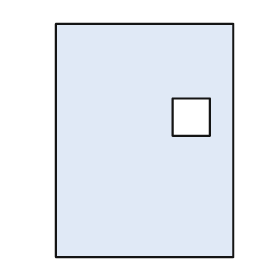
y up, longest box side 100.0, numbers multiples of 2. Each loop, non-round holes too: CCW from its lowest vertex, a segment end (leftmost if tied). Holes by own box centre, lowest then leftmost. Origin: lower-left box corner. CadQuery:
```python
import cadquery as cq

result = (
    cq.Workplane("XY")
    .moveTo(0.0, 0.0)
    .lineTo(76.0, 0.0)
    .lineTo(76.0, 100.0)
    .lineTo(0.0, 100.0)
    .close()
    .moveTo(50.0, 52.0)
    .lineTo(66.0, 52.0)
    .lineTo(66.0, 68.0)
    .lineTo(50.0, 68.0)
    .close()
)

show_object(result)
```